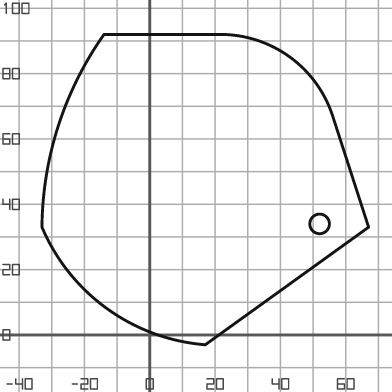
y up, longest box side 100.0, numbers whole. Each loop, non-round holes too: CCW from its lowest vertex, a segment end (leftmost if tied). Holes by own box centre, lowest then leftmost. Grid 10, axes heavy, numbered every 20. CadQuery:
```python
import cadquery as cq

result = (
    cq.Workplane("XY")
    .moveTo(17.0, -3.0)
    .lineTo(67.0, 33.0)
    .lineTo(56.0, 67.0)
    .threePointArc((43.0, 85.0), (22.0, 92.0))
    .lineTo(-14.0, 92.0)
    .threePointArc((-28.0, 64.0), (-33.0, 33.0))
    .threePointArc((-13.0, 8.0), (17.0, -3.0))
    .close()
    .moveTo(52.0, 34.0)
    .circle(3.0)
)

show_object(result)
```